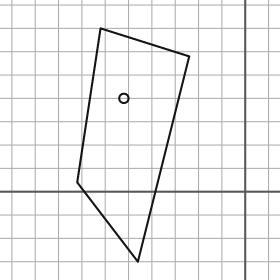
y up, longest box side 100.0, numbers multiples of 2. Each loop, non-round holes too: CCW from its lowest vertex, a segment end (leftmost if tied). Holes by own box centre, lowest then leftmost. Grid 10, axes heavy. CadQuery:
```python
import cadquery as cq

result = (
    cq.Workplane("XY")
    .moveTo(-46.0, -30.0)
    .lineTo(-24.0, 58.0)
    .lineTo(-62.0, 70.0)
    .lineTo(-72.0, 4.0)
    .close()
    .moveTo(-52.0, 40.0)
    .circle(2.0)
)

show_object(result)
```